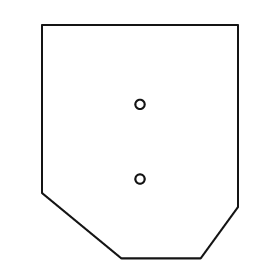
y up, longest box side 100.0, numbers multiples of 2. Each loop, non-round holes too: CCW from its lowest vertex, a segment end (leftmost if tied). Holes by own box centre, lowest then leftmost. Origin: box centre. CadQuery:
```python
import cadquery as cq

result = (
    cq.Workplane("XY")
    .moveTo(-8.0, -50.0)
    .lineTo(26.0, -50.0)
    .lineTo(42.0, -28.0)
    .lineTo(42.0, 50.0)
    .lineTo(-42.0, 50.0)
    .lineTo(-42.0, -22.0)
    .close()
    .moveTo(0.0, -16.0)
    .circle(2.0)
    .moveTo(0.0, 16.0)
    .circle(2.0)
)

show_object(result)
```